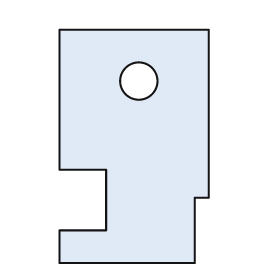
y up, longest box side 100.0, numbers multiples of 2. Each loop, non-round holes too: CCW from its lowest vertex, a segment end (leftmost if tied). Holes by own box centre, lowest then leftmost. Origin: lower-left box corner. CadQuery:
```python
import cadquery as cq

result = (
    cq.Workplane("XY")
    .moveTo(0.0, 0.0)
    .lineTo(58.0, 0.0)
    .lineTo(58.0, 28.0)
    .lineTo(64.0, 28.0)
    .lineTo(64.0, 100.0)
    .lineTo(0.0, 100.0)
    .lineTo(0.0, 40.0)
    .lineTo(20.0, 40.0)
    .lineTo(20.0, 14.0)
    .lineTo(0.0, 14.0)
    .close()
    .moveTo(34.0, 78.0)
    .circle(8.0)
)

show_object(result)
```